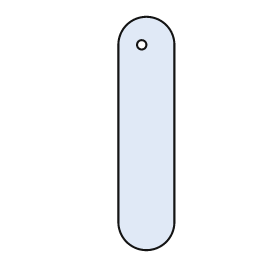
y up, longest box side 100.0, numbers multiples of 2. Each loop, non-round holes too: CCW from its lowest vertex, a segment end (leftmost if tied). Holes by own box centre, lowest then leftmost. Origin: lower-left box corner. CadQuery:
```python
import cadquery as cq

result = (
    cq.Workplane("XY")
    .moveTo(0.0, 12.0)
    .threePointArc((12.0, 0.0), (24.0, 12.0))
    .lineTo(24.0, 88.0)
    .threePointArc((12.0, 100.0), (0.0, 88.0))
    .close()
    .moveTo(10.0, 88.0)
    .circle(2.0)
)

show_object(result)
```